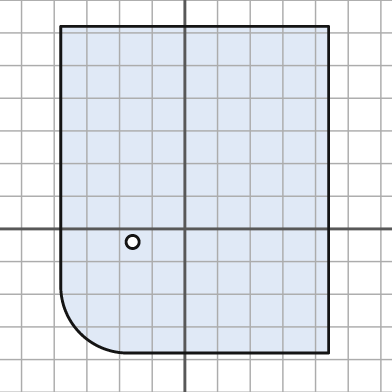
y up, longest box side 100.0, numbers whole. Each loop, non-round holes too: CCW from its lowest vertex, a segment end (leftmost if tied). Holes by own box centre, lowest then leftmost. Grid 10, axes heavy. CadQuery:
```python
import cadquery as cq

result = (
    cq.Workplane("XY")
    .moveTo(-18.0, -38.0)
    .lineTo(44.0, -38.0)
    .lineTo(44.0, 62.0)
    .lineTo(-38.0, 62.0)
    .lineTo(-38.0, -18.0)
    .threePointArc((-32.0, -32.0), (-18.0, -38.0))
    .close()
    .moveTo(-16.0, -4.0)
    .circle(2.0)
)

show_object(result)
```